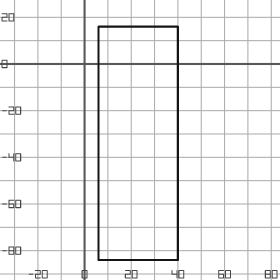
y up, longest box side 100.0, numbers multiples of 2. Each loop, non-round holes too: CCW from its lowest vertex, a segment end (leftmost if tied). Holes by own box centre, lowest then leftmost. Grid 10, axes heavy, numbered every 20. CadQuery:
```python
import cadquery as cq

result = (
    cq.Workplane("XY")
    .moveTo(6.0, -84.0)
    .lineTo(40.0, -84.0)
    .lineTo(40.0, 16.0)
    .lineTo(6.0, 16.0)
    .close()
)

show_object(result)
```